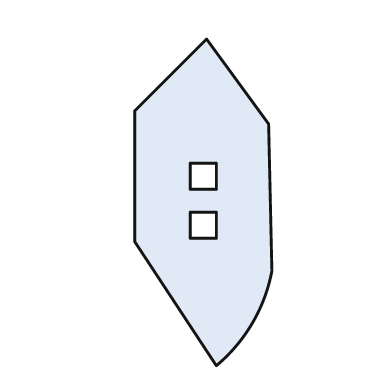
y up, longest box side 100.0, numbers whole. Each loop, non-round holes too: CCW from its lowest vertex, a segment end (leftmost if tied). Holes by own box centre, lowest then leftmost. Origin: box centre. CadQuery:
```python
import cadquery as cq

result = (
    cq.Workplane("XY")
    .moveTo(4.0, -50.0)
    .threePointArc((15.0, -37.0), (21.0, -21.0))
    .lineTo(20.0, 24.0)
    .lineTo(1.0, 50.0)
    .lineTo(-21.0, 28.0)
    .lineTo(-21.0, -12.0)
    .close()
    .moveTo(-4.0, -11.0)
    .lineTo(4.0, -11.0)
    .lineTo(4.0, -3.0)
    .lineTo(-4.0, -3.0)
    .close()
    .moveTo(-4.0, 4.0)
    .lineTo(4.0, 4.0)
    .lineTo(4.0, 12.0)
    .lineTo(-4.0, 12.0)
    .close()
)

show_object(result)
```